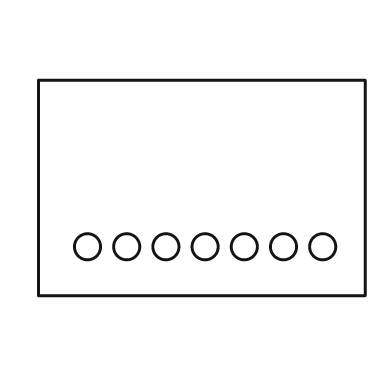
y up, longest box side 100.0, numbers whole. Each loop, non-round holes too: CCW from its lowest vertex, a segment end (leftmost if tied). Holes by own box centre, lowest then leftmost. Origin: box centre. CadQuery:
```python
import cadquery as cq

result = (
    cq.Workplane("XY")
    .moveTo(-50.0, -33.0)
    .lineTo(50.0, -33.0)
    .lineTo(50.0, 33.0)
    .lineTo(-50.0, 33.0)
    .close()
    .moveTo(-35.0, -18.0)
    .circle(4.0)
    .moveTo(-23.0, -18.0)
    .circle(4.0)
    .moveTo(-11.0, -18.0)
    .circle(4.0)
    .moveTo(1.0, -18.0)
    .circle(4.0)
    .moveTo(13.0, -18.0)
    .circle(4.0)
    .moveTo(25.0, -18.0)
    .circle(4.0)
    .moveTo(37.0, -18.0)
    .circle(4.0)
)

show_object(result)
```